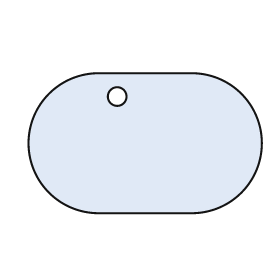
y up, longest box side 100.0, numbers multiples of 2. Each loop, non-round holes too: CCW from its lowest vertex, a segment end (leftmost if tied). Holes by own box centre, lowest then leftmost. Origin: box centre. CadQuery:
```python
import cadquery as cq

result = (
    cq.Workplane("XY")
    .moveTo(-20.0, -30.0)
    .lineTo(20.0, -30.0)
    .threePointArc((50.0, 0.0), (20.0, 30.0))
    .lineTo(-20.0, 30.0)
    .threePointArc((-50.0, 0.0), (-20.0, -30.0))
    .close()
    .moveTo(-12.0, 20.0)
    .circle(4.0)
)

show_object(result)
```